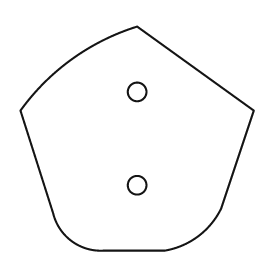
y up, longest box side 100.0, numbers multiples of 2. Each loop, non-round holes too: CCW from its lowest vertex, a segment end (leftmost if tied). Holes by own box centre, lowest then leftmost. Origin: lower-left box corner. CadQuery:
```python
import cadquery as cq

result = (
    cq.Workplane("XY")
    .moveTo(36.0, 0.0)
    .lineTo(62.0, 0.0)
    .threePointArc((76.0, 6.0), (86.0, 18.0))
    .lineTo(100.0, 60.0)
    .lineTo(50.0, 96.0)
    .threePointArc((22.0, 82.0), (0.0, 60.0))
    .lineTo(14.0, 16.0)
    .threePointArc((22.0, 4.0), (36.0, 0.0))
    .close()
    .moveTo(50.0, 28.0)
    .circle(4.0)
    .moveTo(50.0, 68.0)
    .circle(4.0)
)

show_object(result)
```